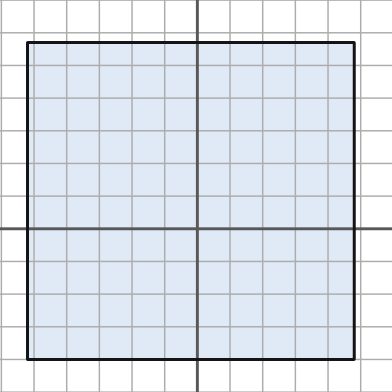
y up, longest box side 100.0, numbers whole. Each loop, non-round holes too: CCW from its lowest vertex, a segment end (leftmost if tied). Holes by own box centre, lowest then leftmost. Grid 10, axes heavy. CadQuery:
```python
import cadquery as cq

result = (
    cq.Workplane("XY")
    .moveTo(-52.0, -40.0)
    .lineTo(48.0, -40.0)
    .lineTo(48.0, 57.0)
    .lineTo(-52.0, 57.0)
    .close()
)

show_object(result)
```